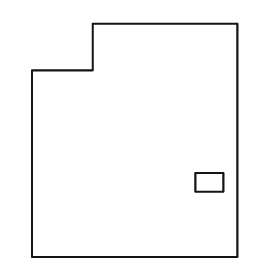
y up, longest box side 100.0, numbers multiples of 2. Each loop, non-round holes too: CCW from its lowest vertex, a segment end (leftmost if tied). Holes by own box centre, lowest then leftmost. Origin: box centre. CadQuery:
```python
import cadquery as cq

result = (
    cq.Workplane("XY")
    .moveTo(-44.0, -50.0)
    .lineTo(44.0, -50.0)
    .lineTo(44.0, 50.0)
    .lineTo(-18.0, 50.0)
    .lineTo(-18.0, 30.0)
    .lineTo(-44.0, 30.0)
    .close()
    .moveTo(26.0, -22.0)
    .lineTo(38.0, -22.0)
    .lineTo(38.0, -14.0)
    .lineTo(26.0, -14.0)
    .close()
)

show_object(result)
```